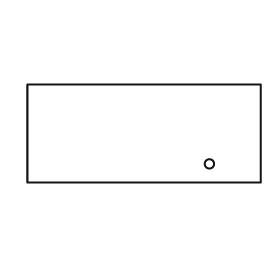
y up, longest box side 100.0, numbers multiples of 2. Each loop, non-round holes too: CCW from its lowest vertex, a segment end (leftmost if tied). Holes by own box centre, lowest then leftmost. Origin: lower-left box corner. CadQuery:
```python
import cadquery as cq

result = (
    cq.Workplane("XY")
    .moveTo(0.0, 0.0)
    .lineTo(100.0, 0.0)
    .lineTo(100.0, 42.0)
    .lineTo(0.0, 42.0)
    .close()
    .moveTo(78.0, 8.0)
    .circle(2.0)
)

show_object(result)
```